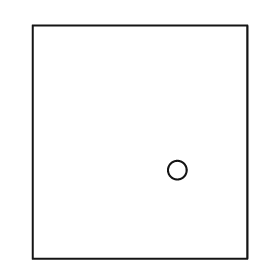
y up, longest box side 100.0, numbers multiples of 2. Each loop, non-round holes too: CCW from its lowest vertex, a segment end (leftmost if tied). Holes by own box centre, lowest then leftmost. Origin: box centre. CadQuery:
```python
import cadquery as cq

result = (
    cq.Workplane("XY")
    .moveTo(-46.0, -50.0)
    .lineTo(46.0, -50.0)
    .lineTo(46.0, 50.0)
    .lineTo(-46.0, 50.0)
    .close()
    .moveTo(16.0, -12.0)
    .circle(4.0)
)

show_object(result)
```